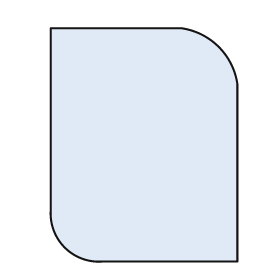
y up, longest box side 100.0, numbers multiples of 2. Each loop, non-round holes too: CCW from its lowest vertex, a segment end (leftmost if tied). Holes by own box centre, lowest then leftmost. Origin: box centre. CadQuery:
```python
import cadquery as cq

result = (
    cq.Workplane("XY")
    .moveTo(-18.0, -50.0)
    .lineTo(40.0, -50.0)
    .lineTo(40.0, 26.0)
    .threePointArc((32.0, 42.0), (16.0, 50.0))
    .lineTo(-40.0, 50.0)
    .lineTo(-40.0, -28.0)
    .threePointArc((-34.0, -44.0), (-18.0, -50.0))
    .close()
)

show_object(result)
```